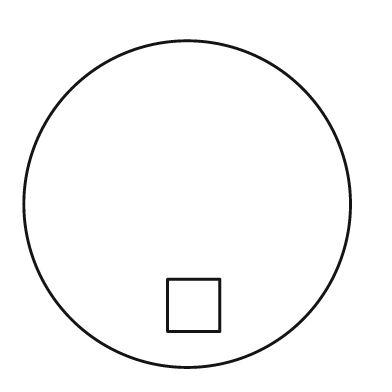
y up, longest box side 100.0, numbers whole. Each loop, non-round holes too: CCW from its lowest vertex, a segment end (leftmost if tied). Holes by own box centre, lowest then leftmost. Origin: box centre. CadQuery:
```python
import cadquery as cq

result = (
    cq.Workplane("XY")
    .moveTo(0.0, 0.0)
    .circle(50.0)
    .moveTo(-6.0, -39.0)
    .lineTo(10.0, -39.0)
    .lineTo(10.0, -23.0)
    .lineTo(-6.0, -23.0)
    .close()
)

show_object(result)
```